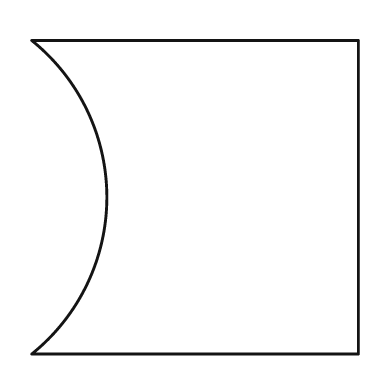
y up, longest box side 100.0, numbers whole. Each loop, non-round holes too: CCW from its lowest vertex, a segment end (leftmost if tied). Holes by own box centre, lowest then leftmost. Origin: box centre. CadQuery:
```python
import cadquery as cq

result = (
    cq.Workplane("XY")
    .moveTo(-50.0, -48.0)
    .lineTo(50.0, -48.0)
    .lineTo(50.0, 48.0)
    .lineTo(-50.0, 48.0)
    .threePointArc((-27.0, 0.0), (-50.0, -48.0))
    .close()
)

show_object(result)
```